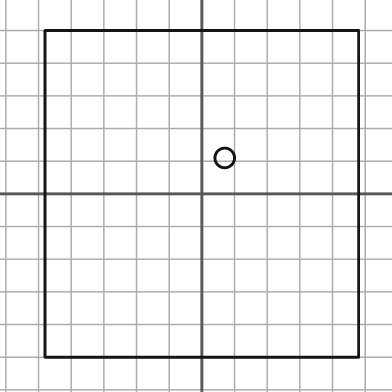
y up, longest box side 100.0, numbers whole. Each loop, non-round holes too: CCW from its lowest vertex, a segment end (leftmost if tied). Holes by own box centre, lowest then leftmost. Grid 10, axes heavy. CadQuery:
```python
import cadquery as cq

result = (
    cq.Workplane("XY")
    .moveTo(-48.0, -50.0)
    .lineTo(48.0, -50.0)
    .lineTo(48.0, 50.0)
    .lineTo(-48.0, 50.0)
    .close()
    .moveTo(7.0, 11.0)
    .circle(3.0)
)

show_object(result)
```